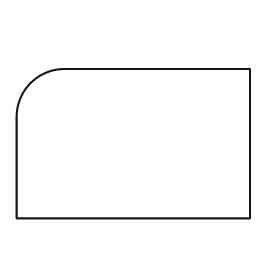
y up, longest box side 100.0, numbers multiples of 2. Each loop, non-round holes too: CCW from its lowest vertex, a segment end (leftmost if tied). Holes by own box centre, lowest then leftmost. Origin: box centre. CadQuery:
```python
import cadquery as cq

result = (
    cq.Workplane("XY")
    .moveTo(-50.0, -32.0)
    .lineTo(50.0, -32.0)
    .lineTo(50.0, 32.0)
    .lineTo(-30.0, 32.0)
    .threePointArc((-44.0, 26.0), (-50.0, 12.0))
    .close()
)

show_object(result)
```